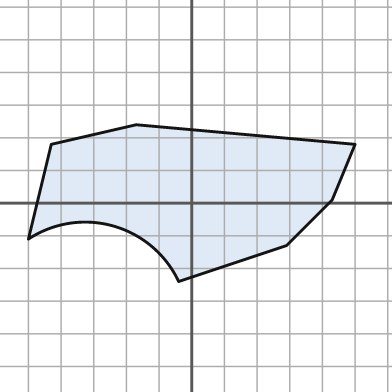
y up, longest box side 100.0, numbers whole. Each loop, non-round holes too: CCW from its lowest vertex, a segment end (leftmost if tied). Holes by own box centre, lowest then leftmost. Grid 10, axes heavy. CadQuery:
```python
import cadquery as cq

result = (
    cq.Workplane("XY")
    .moveTo(-4.0, -24.0)
    .lineTo(29.0, -13.0)
    .lineTo(43.0, 1.0)
    .lineTo(50.0, 18.0)
    .lineTo(-17.0, 24.0)
    .lineTo(-43.0, 18.0)
    .lineTo(-50.0, -11.0)
    .threePointArc((-24.0, -7.0), (-4.0, -24.0))
    .close()
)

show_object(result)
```